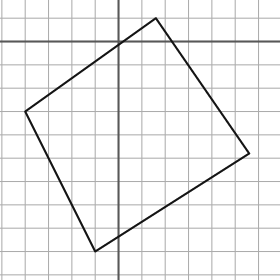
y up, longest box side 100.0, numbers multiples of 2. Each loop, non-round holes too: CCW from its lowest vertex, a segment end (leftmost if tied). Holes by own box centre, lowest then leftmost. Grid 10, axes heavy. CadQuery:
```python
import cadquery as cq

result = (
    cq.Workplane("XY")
    .moveTo(-10.0, -90.0)
    .lineTo(56.0, -48.0)
    .lineTo(16.0, 10.0)
    .lineTo(-40.0, -30.0)
    .close()
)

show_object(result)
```